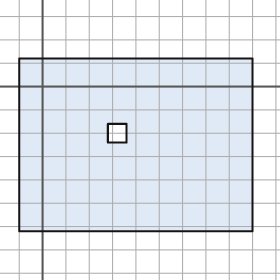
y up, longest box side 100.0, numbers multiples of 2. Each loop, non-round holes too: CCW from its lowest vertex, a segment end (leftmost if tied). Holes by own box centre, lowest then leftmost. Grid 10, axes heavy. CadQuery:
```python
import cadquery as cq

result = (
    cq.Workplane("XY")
    .moveTo(-10.0, -62.0)
    .lineTo(90.0, -62.0)
    .lineTo(90.0, 12.0)
    .lineTo(-10.0, 12.0)
    .close()
    .moveTo(28.0, -24.0)
    .lineTo(36.0, -24.0)
    .lineTo(36.0, -16.0)
    .lineTo(28.0, -16.0)
    .close()
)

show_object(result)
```